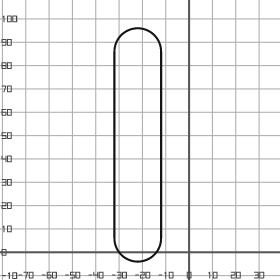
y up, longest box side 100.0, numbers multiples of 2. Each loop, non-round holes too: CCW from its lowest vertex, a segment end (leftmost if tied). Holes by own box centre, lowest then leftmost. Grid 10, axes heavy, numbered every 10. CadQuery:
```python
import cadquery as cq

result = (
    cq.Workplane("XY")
    .moveTo(-32.0, 6.0)
    .threePointArc((-22.0, -4.0), (-12.0, 6.0))
    .lineTo(-12.0, 86.0)
    .threePointArc((-22.0, 96.0), (-32.0, 86.0))
    .close()
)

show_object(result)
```